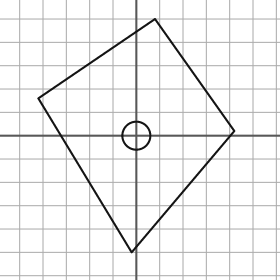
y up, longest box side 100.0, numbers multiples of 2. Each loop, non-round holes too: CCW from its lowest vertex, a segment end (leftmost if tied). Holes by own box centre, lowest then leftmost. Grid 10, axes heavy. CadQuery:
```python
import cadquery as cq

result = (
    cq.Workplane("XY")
    .moveTo(-2.0, -50.0)
    .lineTo(42.0, 2.0)
    .lineTo(8.0, 50.0)
    .lineTo(-42.0, 16.0)
    .close()
    .moveTo(0.0, 0.0)
    .circle(6.0)
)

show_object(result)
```